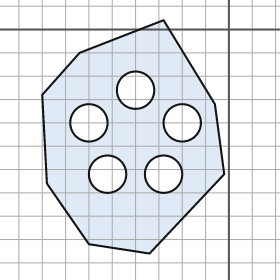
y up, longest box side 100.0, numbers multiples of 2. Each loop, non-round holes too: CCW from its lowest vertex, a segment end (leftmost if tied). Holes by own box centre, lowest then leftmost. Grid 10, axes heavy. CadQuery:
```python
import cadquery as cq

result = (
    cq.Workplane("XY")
    .moveTo(-34.0, -96.0)
    .lineTo(-2.0, -62.0)
    .lineTo(-6.0, -32.0)
    .lineTo(-28.0, 4.0)
    .lineTo(-64.0, -10.0)
    .lineTo(-80.0, -28.0)
    .lineTo(-78.0, -66.0)
    .lineTo(-60.0, -92.0)
    .close()
    .moveTo(-52.0, -62.0)
    .circle(8.0)
    .moveTo(-28.0, -62.0)
    .circle(8.0)
    .moveTo(-60.0, -40.0)
    .circle(8.0)
    .moveTo(-20.0, -40.0)
    .circle(8.0)
    .moveTo(-40.0, -26.0)
    .circle(8.0)
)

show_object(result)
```